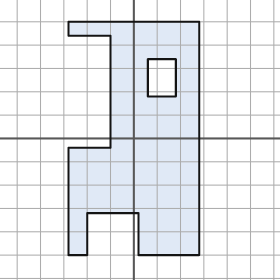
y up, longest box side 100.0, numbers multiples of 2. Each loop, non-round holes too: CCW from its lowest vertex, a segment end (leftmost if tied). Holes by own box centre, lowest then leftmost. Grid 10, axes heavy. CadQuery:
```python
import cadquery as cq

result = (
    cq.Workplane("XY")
    .moveTo(-28.0, -50.0)
    .lineTo(-20.0, -50.0)
    .lineTo(-20.0, -32.0)
    .lineTo(2.0, -32.0)
    .lineTo(2.0, -50.0)
    .lineTo(28.0, -50.0)
    .lineTo(28.0, 50.0)
    .lineTo(-28.0, 50.0)
    .lineTo(-28.0, 44.0)
    .lineTo(-10.0, 44.0)
    .lineTo(-10.0, -4.0)
    .lineTo(-28.0, -4.0)
    .close()
    .moveTo(6.0, 18.0)
    .lineTo(18.0, 18.0)
    .lineTo(18.0, 34.0)
    .lineTo(6.0, 34.0)
    .close()
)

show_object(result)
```